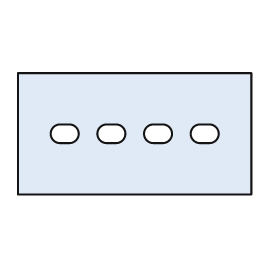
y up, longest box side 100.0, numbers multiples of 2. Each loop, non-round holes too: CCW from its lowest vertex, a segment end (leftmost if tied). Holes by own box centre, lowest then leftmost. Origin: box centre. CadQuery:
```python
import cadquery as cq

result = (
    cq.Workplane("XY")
    .moveTo(-50.0, -26.0)
    .lineTo(50.0, -26.0)
    .lineTo(50.0, 26.0)
    .lineTo(-50.0, 26.0)
    .close()
    .moveTo(-32.0, -4.0)
    .lineTo(-28.0, -4.0)
    .threePointArc((-24.0, 0.0), (-28.0, 4.0))
    .lineTo(-32.0, 4.0)
    .threePointArc((-36.0, 0.0), (-32.0, -4.0))
    .close()
    .moveTo(-12.0, -4.0)
    .lineTo(-8.0, -4.0)
    .threePointArc((-4.0, 0.0), (-8.0, 4.0))
    .lineTo(-12.0, 4.0)
    .threePointArc((-16.0, 0.0), (-12.0, -4.0))
    .close()
    .moveTo(8.0, -4.0)
    .lineTo(12.0, -4.0)
    .threePointArc((16.0, 0.0), (12.0, 4.0))
    .lineTo(8.0, 4.0)
    .threePointArc((4.0, 0.0), (8.0, -4.0))
    .close()
    .moveTo(28.0, -4.0)
    .lineTo(32.0, -4.0)
    .threePointArc((36.0, 0.0), (32.0, 4.0))
    .lineTo(28.0, 4.0)
    .threePointArc((24.0, 0.0), (28.0, -4.0))
    .close()
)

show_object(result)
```